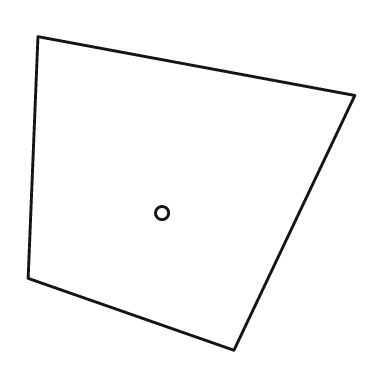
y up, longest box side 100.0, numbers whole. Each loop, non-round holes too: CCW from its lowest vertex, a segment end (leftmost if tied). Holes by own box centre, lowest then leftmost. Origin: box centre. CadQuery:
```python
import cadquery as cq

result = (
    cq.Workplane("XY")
    .moveTo(13.0, -48.0)
    .lineTo(50.0, 30.0)
    .lineTo(-47.0, 48.0)
    .lineTo(-50.0, -26.0)
    .close()
    .moveTo(-9.0, -6.0)
    .circle(2.0)
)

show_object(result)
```